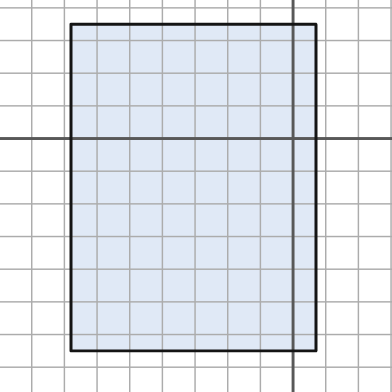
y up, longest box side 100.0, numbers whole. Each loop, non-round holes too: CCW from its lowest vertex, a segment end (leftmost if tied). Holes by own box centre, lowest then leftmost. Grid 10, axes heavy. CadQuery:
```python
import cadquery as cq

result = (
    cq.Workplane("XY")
    .moveTo(-68.0, -65.0)
    .lineTo(7.0, -65.0)
    .lineTo(7.0, 35.0)
    .lineTo(-68.0, 35.0)
    .close()
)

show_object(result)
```